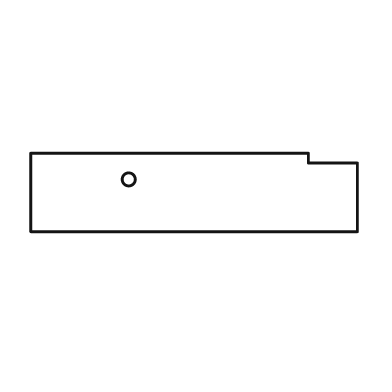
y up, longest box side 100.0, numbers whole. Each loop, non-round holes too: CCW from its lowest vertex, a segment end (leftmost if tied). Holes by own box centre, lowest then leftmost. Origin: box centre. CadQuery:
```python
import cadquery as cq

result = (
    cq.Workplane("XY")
    .moveTo(-50.0, -12.0)
    .lineTo(50.0, -12.0)
    .lineTo(50.0, 9.0)
    .lineTo(35.0, 9.0)
    .lineTo(35.0, 12.0)
    .lineTo(-50.0, 12.0)
    .close()
    .moveTo(-20.0, 4.0)
    .circle(2.0)
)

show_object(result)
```